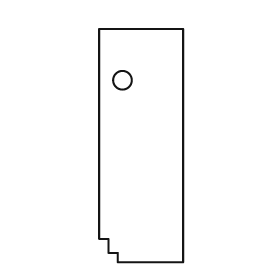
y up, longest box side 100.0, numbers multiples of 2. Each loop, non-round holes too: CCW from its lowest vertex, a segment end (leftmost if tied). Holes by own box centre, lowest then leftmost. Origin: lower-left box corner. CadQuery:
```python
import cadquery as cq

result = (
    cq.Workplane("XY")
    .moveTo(8.0, 0.0)
    .lineTo(36.0, 0.0)
    .lineTo(36.0, 100.0)
    .lineTo(0.0, 100.0)
    .lineTo(0.0, 10.0)
    .lineTo(4.0, 10.0)
    .lineTo(4.0, 4.0)
    .lineTo(8.0, 4.0)
    .close()
    .moveTo(10.0, 78.0)
    .circle(4.0)
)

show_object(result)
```